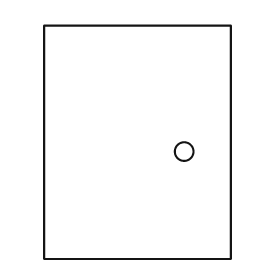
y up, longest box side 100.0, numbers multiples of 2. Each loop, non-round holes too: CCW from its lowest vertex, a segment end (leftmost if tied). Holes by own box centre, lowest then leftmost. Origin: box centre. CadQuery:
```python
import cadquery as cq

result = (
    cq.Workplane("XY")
    .moveTo(-40.0, -50.0)
    .lineTo(40.0, -50.0)
    .lineTo(40.0, 50.0)
    .lineTo(-40.0, 50.0)
    .close()
    .moveTo(20.0, -4.0)
    .circle(4.0)
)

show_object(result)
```